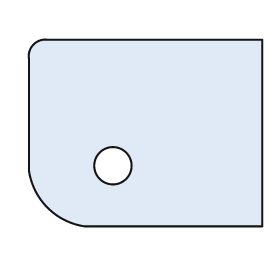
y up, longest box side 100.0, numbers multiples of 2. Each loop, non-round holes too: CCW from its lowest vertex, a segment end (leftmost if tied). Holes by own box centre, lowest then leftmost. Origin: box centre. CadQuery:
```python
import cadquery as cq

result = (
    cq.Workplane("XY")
    .moveTo(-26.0, -40.0)
    .lineTo(50.0, -40.0)
    .lineTo(50.0, 40.0)
    .lineTo(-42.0, 40.0)
    .threePointArc((-48.0, 38.0), (-50.0, 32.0))
    .lineTo(-50.0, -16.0)
    .threePointArc((-42.0, -32.0), (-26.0, -40.0))
    .close()
    .moveTo(-14.0, -14.0)
    .circle(8.0)
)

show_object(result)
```